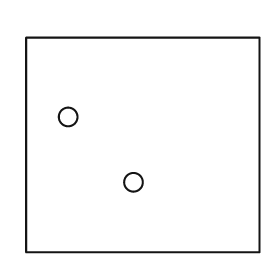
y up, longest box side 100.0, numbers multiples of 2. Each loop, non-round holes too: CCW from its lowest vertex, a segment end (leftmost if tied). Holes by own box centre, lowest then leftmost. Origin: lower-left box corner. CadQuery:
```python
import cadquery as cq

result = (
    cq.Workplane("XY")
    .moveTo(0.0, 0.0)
    .lineTo(100.0, 0.0)
    .lineTo(100.0, 92.0)
    .lineTo(0.0, 92.0)
    .close()
    .moveTo(46.0, 30.0)
    .circle(4.0)
    .moveTo(18.0, 58.0)
    .circle(4.0)
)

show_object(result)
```